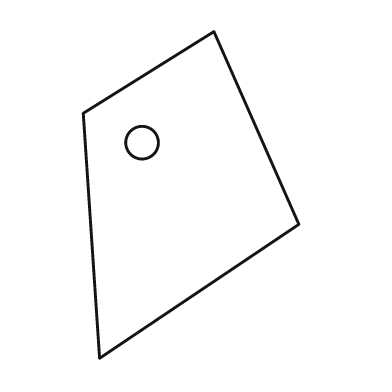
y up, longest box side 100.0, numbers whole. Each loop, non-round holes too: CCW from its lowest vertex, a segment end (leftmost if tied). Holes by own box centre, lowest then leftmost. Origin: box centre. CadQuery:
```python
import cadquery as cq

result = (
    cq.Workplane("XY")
    .moveTo(-28.0, -50.0)
    .lineTo(33.0, -9.0)
    .lineTo(7.0, 50.0)
    .lineTo(-33.0, 25.0)
    .close()
    .moveTo(-15.0, 16.0)
    .circle(5.0)
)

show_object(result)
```